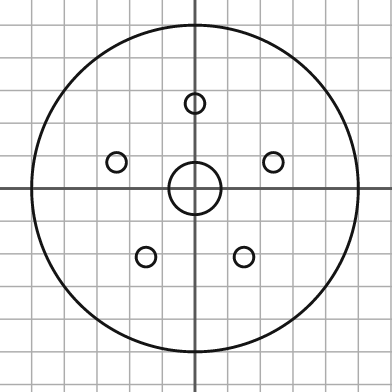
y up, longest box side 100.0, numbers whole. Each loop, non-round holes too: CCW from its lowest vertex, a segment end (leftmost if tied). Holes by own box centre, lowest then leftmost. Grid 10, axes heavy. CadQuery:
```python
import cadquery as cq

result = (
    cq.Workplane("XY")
    .moveTo(0.0, 0.0)
    .circle(50.0)
    .moveTo(-15.0, -21.0)
    .circle(3.0)
    .moveTo(15.0, -21.0)
    .circle(3.0)
    .moveTo(0.0, 0.0)
    .circle(8.0)
    .moveTo(-24.0, 8.0)
    .circle(3.0)
    .moveTo(24.0, 8.0)
    .circle(3.0)
    .moveTo(0.0, 26.0)
    .circle(3.0)
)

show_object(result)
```